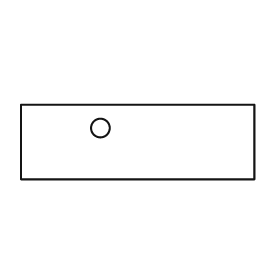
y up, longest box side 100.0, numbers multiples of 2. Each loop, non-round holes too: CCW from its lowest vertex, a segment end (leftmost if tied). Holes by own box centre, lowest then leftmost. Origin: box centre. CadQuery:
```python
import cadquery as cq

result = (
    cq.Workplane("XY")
    .moveTo(-50.0, -16.0)
    .lineTo(50.0, -16.0)
    .lineTo(50.0, 16.0)
    .lineTo(-50.0, 16.0)
    .close()
    .moveTo(-16.0, 6.0)
    .circle(4.0)
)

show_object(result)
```